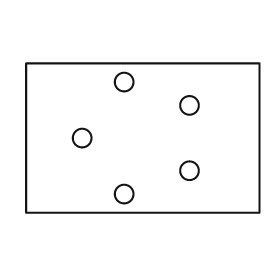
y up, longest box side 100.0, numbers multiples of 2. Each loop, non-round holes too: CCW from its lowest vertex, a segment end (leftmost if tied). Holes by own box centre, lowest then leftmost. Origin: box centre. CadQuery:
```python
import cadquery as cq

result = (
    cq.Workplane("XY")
    .moveTo(-50.0, -32.0)
    .lineTo(50.0, -32.0)
    .lineTo(50.0, 32.0)
    .lineTo(-50.0, 32.0)
    .close()
    .moveTo(-8.0, -24.0)
    .circle(4.0)
    .moveTo(20.0, -14.0)
    .circle(4.0)
    .moveTo(-26.0, 0.0)
    .circle(4.0)
    .moveTo(20.0, 14.0)
    .circle(4.0)
    .moveTo(-8.0, 24.0)
    .circle(4.0)
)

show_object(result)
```